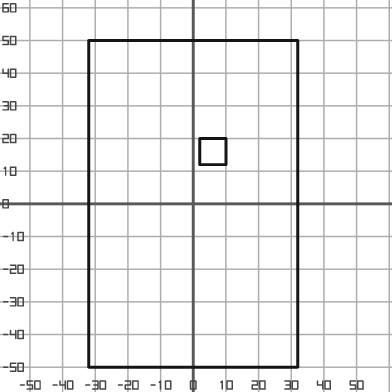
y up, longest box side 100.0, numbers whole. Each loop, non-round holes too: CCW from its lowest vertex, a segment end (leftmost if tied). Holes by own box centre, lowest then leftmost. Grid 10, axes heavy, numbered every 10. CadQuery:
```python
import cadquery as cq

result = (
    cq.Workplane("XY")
    .moveTo(-32.0, -50.0)
    .lineTo(32.0, -50.0)
    .lineTo(32.0, 50.0)
    .lineTo(-32.0, 50.0)
    .close()
    .moveTo(2.0, 12.0)
    .lineTo(10.0, 12.0)
    .lineTo(10.0, 20.0)
    .lineTo(2.0, 20.0)
    .close()
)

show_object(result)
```